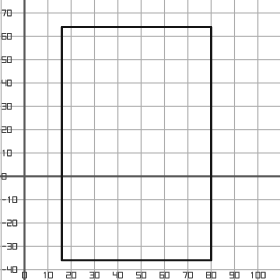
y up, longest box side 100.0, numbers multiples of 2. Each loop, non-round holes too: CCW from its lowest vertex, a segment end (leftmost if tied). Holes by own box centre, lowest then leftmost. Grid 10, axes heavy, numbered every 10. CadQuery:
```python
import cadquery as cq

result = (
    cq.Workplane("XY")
    .moveTo(16.0, -36.0)
    .lineTo(80.0, -36.0)
    .lineTo(80.0, 64.0)
    .lineTo(16.0, 64.0)
    .close()
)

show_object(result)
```